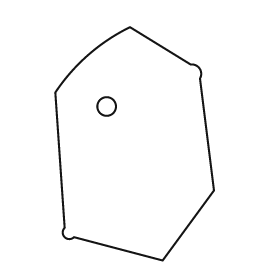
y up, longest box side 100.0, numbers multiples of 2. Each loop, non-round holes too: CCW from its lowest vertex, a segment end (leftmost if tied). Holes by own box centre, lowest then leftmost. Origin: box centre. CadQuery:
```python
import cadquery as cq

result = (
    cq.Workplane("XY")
    .moveTo(12.0, -50.0)
    .lineTo(34.0, -20.0)
    .lineTo(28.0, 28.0)
    .threePointArc((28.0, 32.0), (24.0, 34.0))
    .lineTo(-2.0, 50.0)
    .threePointArc((-20.0, 38.0), (-34.0, 22.0))
    .lineTo(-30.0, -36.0)
    .threePointArc((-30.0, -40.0), (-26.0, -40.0))
    .close()
    .moveTo(-12.0, 16.0)
    .circle(4.0)
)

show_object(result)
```